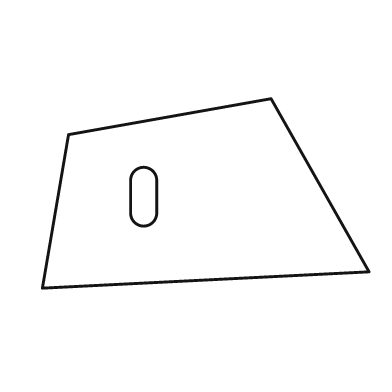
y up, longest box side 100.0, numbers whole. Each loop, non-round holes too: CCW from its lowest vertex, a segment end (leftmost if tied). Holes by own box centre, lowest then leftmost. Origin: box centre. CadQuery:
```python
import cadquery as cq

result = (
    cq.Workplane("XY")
    .moveTo(-50.0, -29.0)
    .lineTo(50.0, -24.0)
    .lineTo(20.0, 29.0)
    .lineTo(-42.0, 18.0)
    .close()
    .moveTo(-23.0, -6.0)
    .threePointArc((-19.0, -10.0), (-15.0, -6.0))
    .lineTo(-15.0, 4.0)
    .threePointArc((-19.0, 8.0), (-23.0, 4.0))
    .close()
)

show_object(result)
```